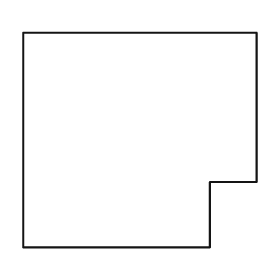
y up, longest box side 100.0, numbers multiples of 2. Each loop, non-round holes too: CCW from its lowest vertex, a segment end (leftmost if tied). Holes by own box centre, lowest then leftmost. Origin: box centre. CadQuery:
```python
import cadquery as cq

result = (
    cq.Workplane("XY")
    .moveTo(-50.0, -46.0)
    .lineTo(30.0, -46.0)
    .lineTo(30.0, -18.0)
    .lineTo(50.0, -18.0)
    .lineTo(50.0, 46.0)
    .lineTo(-50.0, 46.0)
    .close()
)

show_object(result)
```